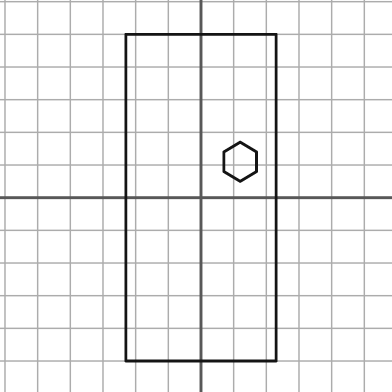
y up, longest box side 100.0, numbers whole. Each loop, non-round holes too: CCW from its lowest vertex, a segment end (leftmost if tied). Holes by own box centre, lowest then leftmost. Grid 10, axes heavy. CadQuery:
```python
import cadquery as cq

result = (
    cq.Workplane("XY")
    .moveTo(-23.0, -50.0)
    .lineTo(23.0, -50.0)
    .lineTo(23.0, 50.0)
    .lineTo(-23.0, 50.0)
    .close()
    .moveTo(12.0, 5.0)
    .lineTo(17.0, 8.0)
    .lineTo(17.0, 14.0)
    .lineTo(12.0, 17.0)
    .lineTo(7.0, 14.0)
    .lineTo(7.0, 8.0)
    .close()
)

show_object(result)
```